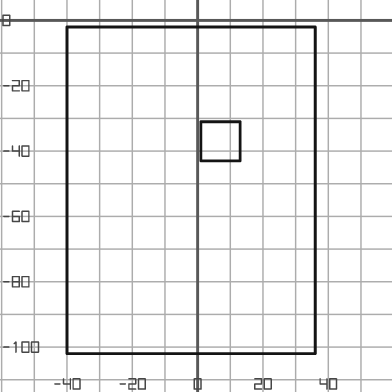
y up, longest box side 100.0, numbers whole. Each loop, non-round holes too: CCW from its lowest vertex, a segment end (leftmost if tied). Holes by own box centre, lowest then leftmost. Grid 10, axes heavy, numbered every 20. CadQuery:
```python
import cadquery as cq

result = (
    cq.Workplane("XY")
    .moveTo(-40.0, -102.0)
    .lineTo(36.0, -102.0)
    .lineTo(36.0, -2.0)
    .lineTo(-40.0, -2.0)
    .close()
    .moveTo(1.0, -43.0)
    .lineTo(13.0, -43.0)
    .lineTo(13.0, -31.0)
    .lineTo(1.0, -31.0)
    .close()
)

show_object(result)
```